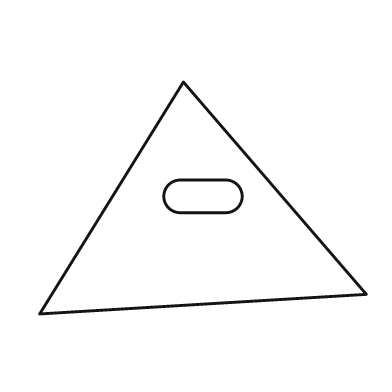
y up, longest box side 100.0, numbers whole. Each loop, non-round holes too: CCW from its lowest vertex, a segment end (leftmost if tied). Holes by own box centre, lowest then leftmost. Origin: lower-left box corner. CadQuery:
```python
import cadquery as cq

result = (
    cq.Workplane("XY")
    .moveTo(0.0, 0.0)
    .lineTo(100.0, 6.0)
    .lineTo(44.0, 71.0)
    .close()
    .moveTo(43.0, 31.0)
    .lineTo(57.0, 31.0)
    .threePointArc((62.0, 36.0), (57.0, 41.0))
    .lineTo(43.0, 41.0)
    .threePointArc((38.0, 36.0), (43.0, 31.0))
    .close()
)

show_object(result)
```